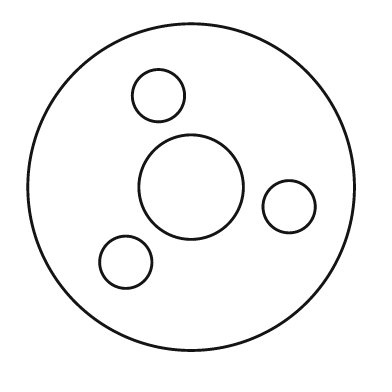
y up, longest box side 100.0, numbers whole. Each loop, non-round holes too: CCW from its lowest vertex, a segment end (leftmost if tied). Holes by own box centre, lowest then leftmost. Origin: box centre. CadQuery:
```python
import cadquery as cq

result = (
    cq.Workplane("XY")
    .moveTo(0.0, 0.0)
    .circle(50.0)
    .moveTo(-20.0, -23.0)
    .circle(8.0)
    .moveTo(30.0, -6.0)
    .circle(8.0)
    .moveTo(0.0, 0.0)
    .circle(16.0)
    .moveTo(-10.0, 28.0)
    .circle(8.0)
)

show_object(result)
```